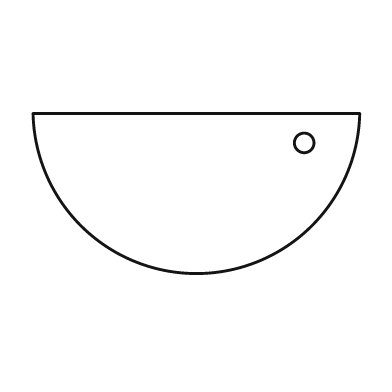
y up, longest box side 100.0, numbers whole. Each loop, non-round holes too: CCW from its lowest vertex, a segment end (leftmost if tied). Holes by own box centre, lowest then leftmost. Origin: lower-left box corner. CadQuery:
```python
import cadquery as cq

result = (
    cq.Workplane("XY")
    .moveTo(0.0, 49.0)
    .threePointArc((50.0, 0.0), (100.0, 49.0))
    .close()
    .moveTo(83.0, 40.0)
    .circle(3.0)
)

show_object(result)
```